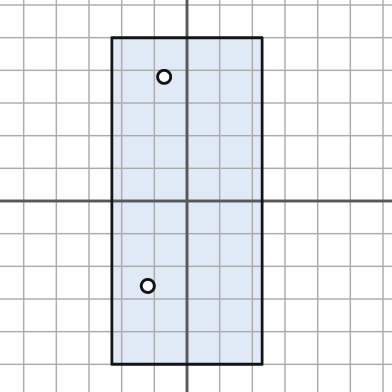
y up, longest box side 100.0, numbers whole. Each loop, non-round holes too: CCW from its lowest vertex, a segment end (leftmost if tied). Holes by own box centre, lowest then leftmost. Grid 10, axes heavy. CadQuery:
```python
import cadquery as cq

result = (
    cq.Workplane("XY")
    .moveTo(-23.0, -50.0)
    .lineTo(23.0, -50.0)
    .lineTo(23.0, 50.0)
    .lineTo(-23.0, 50.0)
    .close()
    .moveTo(-12.0, -26.0)
    .circle(2.0)
    .moveTo(-7.0, 38.0)
    .circle(2.0)
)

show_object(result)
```